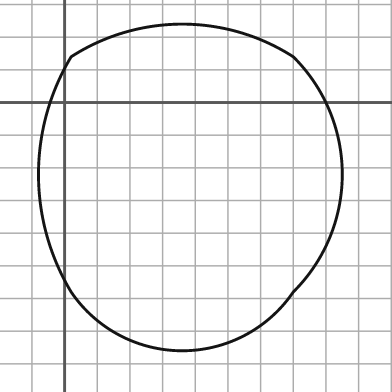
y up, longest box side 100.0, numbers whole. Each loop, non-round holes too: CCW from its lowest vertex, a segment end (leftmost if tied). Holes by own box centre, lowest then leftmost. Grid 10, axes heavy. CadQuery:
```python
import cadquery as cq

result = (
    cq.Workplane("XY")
    .moveTo(2.0, -58.0)
    .threePointArc((36.0, -76.0), (70.0, -58.0))
    .threePointArc((85.0, -22.0), (70.0, 14.0))
    .threePointArc((36.0, 24.0), (2.0, 14.0))
    .threePointArc((-8.0, -22.0), (2.0, -58.0))
    .close()
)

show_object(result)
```